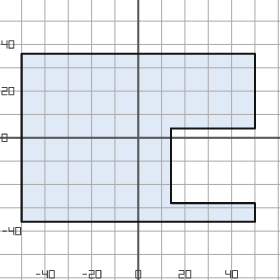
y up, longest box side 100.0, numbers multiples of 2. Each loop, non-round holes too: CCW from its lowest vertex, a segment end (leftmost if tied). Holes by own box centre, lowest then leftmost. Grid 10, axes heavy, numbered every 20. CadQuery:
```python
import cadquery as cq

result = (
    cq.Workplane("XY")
    .moveTo(-50.0, -36.0)
    .lineTo(50.0, -36.0)
    .lineTo(50.0, -28.0)
    .lineTo(14.0, -28.0)
    .lineTo(14.0, 4.0)
    .lineTo(50.0, 4.0)
    .lineTo(50.0, 36.0)
    .lineTo(-50.0, 36.0)
    .close()
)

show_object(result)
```